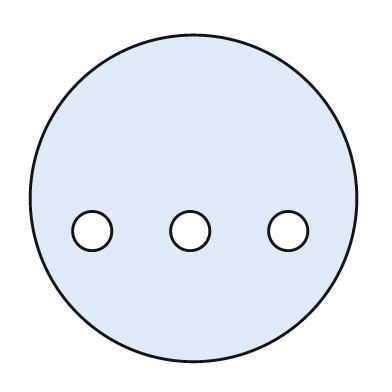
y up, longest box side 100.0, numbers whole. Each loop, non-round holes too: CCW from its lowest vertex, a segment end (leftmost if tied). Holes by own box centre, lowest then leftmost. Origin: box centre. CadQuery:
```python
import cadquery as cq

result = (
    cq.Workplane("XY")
    .moveTo(0.0, 0.0)
    .circle(50.0)
    .moveTo(-31.0, -10.0)
    .circle(6.0)
    .moveTo(-1.0, -10.0)
    .circle(6.0)
    .moveTo(29.0, -10.0)
    .circle(6.0)
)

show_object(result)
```